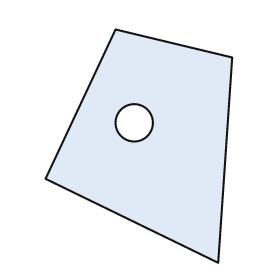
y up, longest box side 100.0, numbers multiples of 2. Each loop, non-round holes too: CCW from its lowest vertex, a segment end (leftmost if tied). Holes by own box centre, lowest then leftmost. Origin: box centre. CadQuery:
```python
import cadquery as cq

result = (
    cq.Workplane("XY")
    .moveTo(34.0, -50.0)
    .lineTo(40.0, 38.0)
    .lineTo(-10.0, 50.0)
    .lineTo(-40.0, -14.0)
    .close()
    .moveTo(-2.0, 10.0)
    .circle(8.0)
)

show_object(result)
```